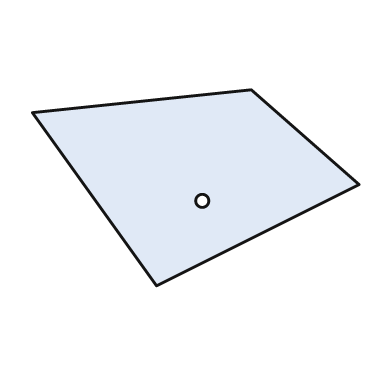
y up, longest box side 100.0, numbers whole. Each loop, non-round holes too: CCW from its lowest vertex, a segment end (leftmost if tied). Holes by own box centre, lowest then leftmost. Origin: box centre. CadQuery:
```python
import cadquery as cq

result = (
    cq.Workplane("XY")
    .moveTo(-12.0, -30.0)
    .lineTo(50.0, 1.0)
    .lineTo(17.0, 30.0)
    .lineTo(-50.0, 23.0)
    .close()
    .moveTo(2.0, -4.0)
    .circle(2.0)
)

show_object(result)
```